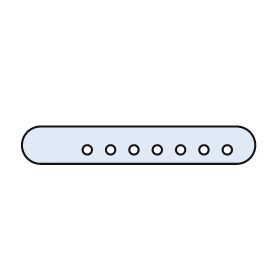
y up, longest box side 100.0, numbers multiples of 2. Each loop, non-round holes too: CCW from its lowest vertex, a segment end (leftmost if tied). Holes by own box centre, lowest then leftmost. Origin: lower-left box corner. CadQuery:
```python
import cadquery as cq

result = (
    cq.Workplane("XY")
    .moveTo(8.0, 0.0)
    .lineTo(92.0, 0.0)
    .threePointArc((100.0, 8.0), (92.0, 16.0))
    .lineTo(8.0, 16.0)
    .threePointArc((0.0, 8.0), (8.0, 0.0))
    .close()
    .moveTo(28.0, 6.0)
    .circle(2.0)
    .moveTo(38.0, 6.0)
    .circle(2.0)
    .moveTo(48.0, 6.0)
    .circle(2.0)
    .moveTo(58.0, 6.0)
    .circle(2.0)
    .moveTo(68.0, 6.0)
    .circle(2.0)
    .moveTo(78.0, 6.0)
    .circle(2.0)
    .moveTo(88.0, 6.0)
    .circle(2.0)
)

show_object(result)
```